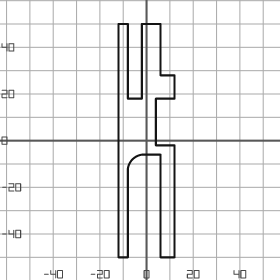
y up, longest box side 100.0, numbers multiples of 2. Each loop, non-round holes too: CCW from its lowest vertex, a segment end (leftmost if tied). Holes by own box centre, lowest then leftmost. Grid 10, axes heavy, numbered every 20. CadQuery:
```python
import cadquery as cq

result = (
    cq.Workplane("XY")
    .moveTo(-12.0, -50.0)
    .lineTo(-8.0, -50.0)
    .lineTo(-8.0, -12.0)
    .threePointArc((-6.0, -8.0), (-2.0, -6.0))
    .lineTo(6.0, -6.0)
    .lineTo(6.0, -50.0)
    .lineTo(12.0, -50.0)
    .lineTo(12.0, -2.0)
    .lineTo(4.0, -2.0)
    .lineTo(4.0, 18.0)
    .lineTo(12.0, 18.0)
    .lineTo(12.0, 28.0)
    .lineTo(6.0, 28.0)
    .lineTo(6.0, 50.0)
    .lineTo(-2.0, 50.0)
    .lineTo(-2.0, 18.0)
    .lineTo(-8.0, 18.0)
    .lineTo(-8.0, 50.0)
    .lineTo(-12.0, 50.0)
    .close()
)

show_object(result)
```